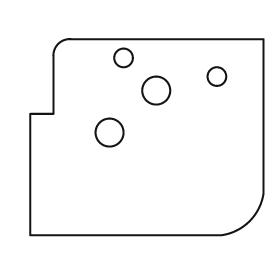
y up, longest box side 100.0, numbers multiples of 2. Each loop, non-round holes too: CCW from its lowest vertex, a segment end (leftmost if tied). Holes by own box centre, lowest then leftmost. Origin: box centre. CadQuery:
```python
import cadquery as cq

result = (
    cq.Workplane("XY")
    .moveTo(-50.0, -42.0)
    .lineTo(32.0, -42.0)
    .threePointArc((44.0, -36.0), (50.0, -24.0))
    .lineTo(50.0, 42.0)
    .lineTo(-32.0, 42.0)
    .threePointArc((-38.0, 40.0), (-40.0, 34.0))
    .lineTo(-40.0, 10.0)
    .lineTo(-50.0, 10.0)
    .close()
    .moveTo(-16.0, 2.0)
    .circle(6.0)
    .moveTo(4.0, 20.0)
    .circle(6.0)
    .moveTo(30.0, 26.0)
    .circle(4.0)
    .moveTo(-10.0, 34.0)
    .circle(4.0)
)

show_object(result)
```